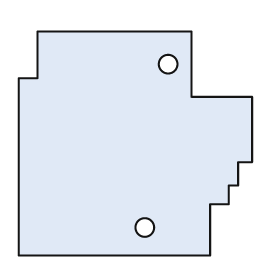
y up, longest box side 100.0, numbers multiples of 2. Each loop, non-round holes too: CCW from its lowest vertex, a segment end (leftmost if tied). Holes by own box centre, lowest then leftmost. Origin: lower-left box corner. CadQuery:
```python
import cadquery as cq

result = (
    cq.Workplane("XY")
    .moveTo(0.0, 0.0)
    .lineTo(82.0, 0.0)
    .lineTo(82.0, 22.0)
    .lineTo(90.0, 22.0)
    .lineTo(90.0, 30.0)
    .lineTo(94.0, 30.0)
    .lineTo(94.0, 40.0)
    .lineTo(100.0, 40.0)
    .lineTo(100.0, 68.0)
    .lineTo(74.0, 68.0)
    .lineTo(74.0, 96.0)
    .lineTo(8.0, 96.0)
    .lineTo(8.0, 76.0)
    .lineTo(0.0, 76.0)
    .close()
    .moveTo(54.0, 12.0)
    .circle(4.0)
    .moveTo(64.0, 82.0)
    .circle(4.0)
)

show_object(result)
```